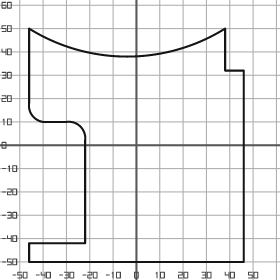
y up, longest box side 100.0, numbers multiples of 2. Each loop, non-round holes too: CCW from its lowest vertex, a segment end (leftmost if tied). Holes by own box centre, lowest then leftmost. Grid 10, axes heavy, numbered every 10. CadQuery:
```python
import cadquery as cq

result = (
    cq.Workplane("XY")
    .moveTo(-46.0, -50.0)
    .lineTo(46.0, -50.0)
    .lineTo(46.0, 32.0)
    .lineTo(38.0, 32.0)
    .lineTo(38.0, 50.0)
    .threePointArc((-4.0, 38.0), (-46.0, 50.0))
    .lineTo(-46.0, 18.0)
    .threePointArc((-44.0, 12.0), (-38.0, 10.0))
    .lineTo(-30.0, 10.0)
    .threePointArc((-24.0, 8.0), (-22.0, 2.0))
    .lineTo(-22.0, -42.0)
    .lineTo(-46.0, -42.0)
    .close()
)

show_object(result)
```